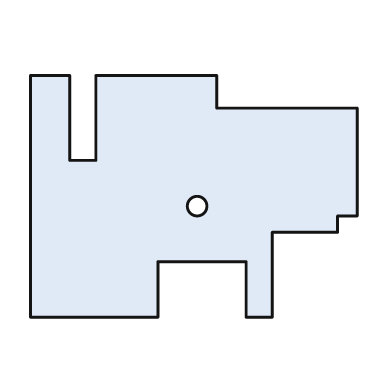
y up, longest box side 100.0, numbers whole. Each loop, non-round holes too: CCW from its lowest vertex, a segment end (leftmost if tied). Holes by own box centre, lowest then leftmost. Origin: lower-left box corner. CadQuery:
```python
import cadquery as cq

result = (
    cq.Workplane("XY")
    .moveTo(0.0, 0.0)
    .lineTo(39.0, 0.0)
    .lineTo(39.0, 17.0)
    .lineTo(66.0, 17.0)
    .lineTo(66.0, 0.0)
    .lineTo(74.0, 0.0)
    .lineTo(74.0, 26.0)
    .lineTo(94.0, 26.0)
    .lineTo(94.0, 31.0)
    .lineTo(100.0, 31.0)
    .lineTo(100.0, 64.0)
    .lineTo(57.0, 64.0)
    .lineTo(57.0, 74.0)
    .lineTo(20.0, 74.0)
    .lineTo(20.0, 48.0)
    .lineTo(12.0, 48.0)
    .lineTo(12.0, 74.0)
    .lineTo(0.0, 74.0)
    .close()
    .moveTo(51.0, 34.0)
    .circle(3.0)
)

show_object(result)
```